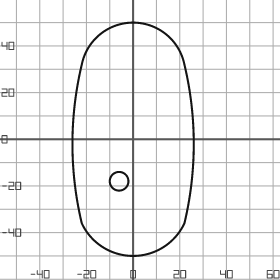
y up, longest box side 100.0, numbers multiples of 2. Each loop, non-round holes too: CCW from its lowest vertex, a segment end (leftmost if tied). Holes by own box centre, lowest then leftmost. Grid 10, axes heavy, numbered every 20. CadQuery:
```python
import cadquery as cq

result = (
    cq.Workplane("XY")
    .moveTo(-22.0, -36.0)
    .threePointArc((0.0, -50.0), (22.0, -36.0))
    .threePointArc((26.0, -2.0), (22.0, 32.0))
    .threePointArc((0.0, 50.0), (-22.0, 32.0))
    .threePointArc((-26.0, -2.0), (-22.0, -36.0))
    .close()
    .moveTo(-6.0, -18.0)
    .circle(4.0)
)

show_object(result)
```